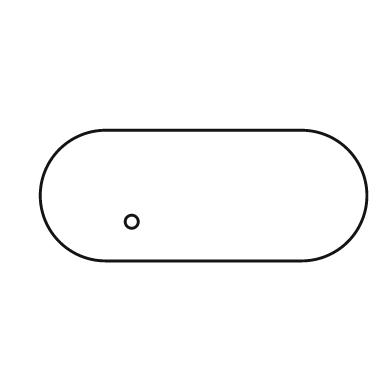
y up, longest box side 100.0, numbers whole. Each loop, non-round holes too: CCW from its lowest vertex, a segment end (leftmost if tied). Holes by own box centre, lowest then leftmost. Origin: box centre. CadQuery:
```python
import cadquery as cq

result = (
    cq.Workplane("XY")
    .moveTo(-30.0, -20.0)
    .lineTo(30.0, -20.0)
    .threePointArc((50.0, 0.0), (30.0, 20.0))
    .lineTo(-30.0, 20.0)
    .threePointArc((-50.0, 0.0), (-30.0, -20.0))
    .close()
    .moveTo(-22.0, -8.0)
    .circle(2.0)
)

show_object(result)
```